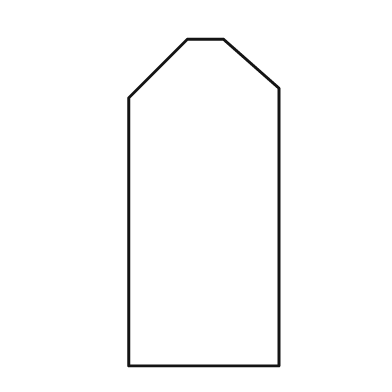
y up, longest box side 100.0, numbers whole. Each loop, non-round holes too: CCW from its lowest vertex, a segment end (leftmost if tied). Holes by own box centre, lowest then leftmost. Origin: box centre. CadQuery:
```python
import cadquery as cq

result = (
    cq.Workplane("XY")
    .moveTo(-23.0, -50.0)
    .lineTo(23.0, -50.0)
    .lineTo(23.0, 35.0)
    .lineTo(6.0, 50.0)
    .lineTo(-5.0, 50.0)
    .lineTo(-23.0, 32.0)
    .close()
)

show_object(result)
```